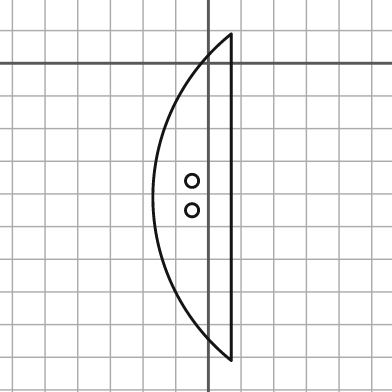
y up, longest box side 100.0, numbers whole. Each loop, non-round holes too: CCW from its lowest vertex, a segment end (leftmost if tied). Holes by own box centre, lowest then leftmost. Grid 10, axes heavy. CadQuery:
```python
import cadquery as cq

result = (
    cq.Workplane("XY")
    .moveTo(7.0, -91.0)
    .lineTo(7.0, 9.0)
    .threePointArc((-17.0, -41.0), (7.0, -91.0))
    .close()
    .moveTo(-5.0, -45.0)
    .circle(2.0)
    .moveTo(-5.0, -36.0)
    .circle(2.0)
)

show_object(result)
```